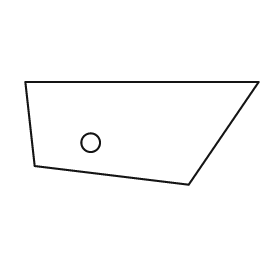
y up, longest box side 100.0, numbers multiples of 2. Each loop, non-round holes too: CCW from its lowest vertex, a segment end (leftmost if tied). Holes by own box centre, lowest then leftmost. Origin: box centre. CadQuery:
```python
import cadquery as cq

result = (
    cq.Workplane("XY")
    .moveTo(20.0, -22.0)
    .lineTo(50.0, 22.0)
    .lineTo(-50.0, 22.0)
    .lineTo(-46.0, -14.0)
    .close()
    .moveTo(-22.0, -4.0)
    .circle(4.0)
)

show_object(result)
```